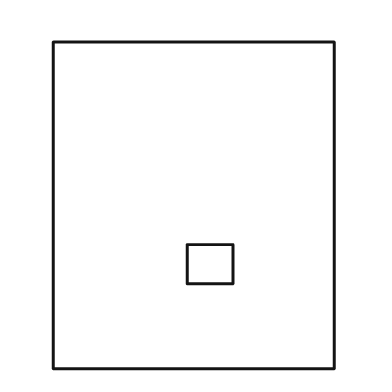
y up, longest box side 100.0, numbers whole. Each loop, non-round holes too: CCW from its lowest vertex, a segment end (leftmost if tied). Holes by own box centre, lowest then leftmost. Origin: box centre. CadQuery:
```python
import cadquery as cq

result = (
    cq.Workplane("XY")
    .moveTo(-43.0, -50.0)
    .lineTo(43.0, -50.0)
    .lineTo(43.0, 50.0)
    .lineTo(-43.0, 50.0)
    .close()
    .moveTo(-2.0, -24.0)
    .lineTo(12.0, -24.0)
    .lineTo(12.0, -12.0)
    .lineTo(-2.0, -12.0)
    .close()
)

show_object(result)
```